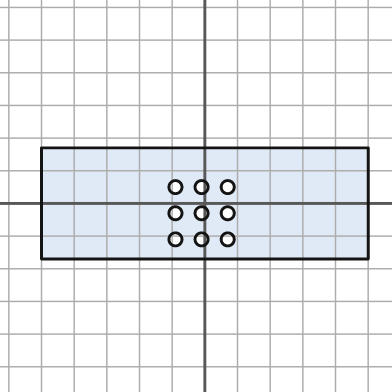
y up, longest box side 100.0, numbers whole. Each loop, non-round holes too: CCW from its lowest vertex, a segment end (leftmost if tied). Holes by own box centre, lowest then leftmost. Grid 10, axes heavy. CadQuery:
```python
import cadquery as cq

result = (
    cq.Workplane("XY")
    .moveTo(-50.0, -17.0)
    .lineTo(50.0, -17.0)
    .lineTo(50.0, 17.0)
    .lineTo(-50.0, 17.0)
    .close()
    .moveTo(-9.0, -11.0)
    .circle(2.0)
    .moveTo(-1.0, -11.0)
    .circle(2.0)
    .moveTo(7.0, -11.0)
    .circle(2.0)
    .moveTo(-9.0, -3.0)
    .circle(2.0)
    .moveTo(-1.0, -3.0)
    .circle(2.0)
    .moveTo(7.0, -3.0)
    .circle(2.0)
    .moveTo(-9.0, 5.0)
    .circle(2.0)
    .moveTo(-1.0, 5.0)
    .circle(2.0)
    .moveTo(7.0, 5.0)
    .circle(2.0)
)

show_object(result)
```